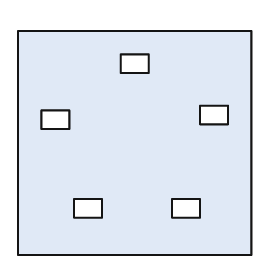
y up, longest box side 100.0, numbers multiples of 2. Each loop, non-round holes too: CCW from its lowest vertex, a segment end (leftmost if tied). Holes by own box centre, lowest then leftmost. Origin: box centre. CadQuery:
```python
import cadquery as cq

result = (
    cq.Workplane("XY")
    .moveTo(-50.0, -48.0)
    .lineTo(50.0, -48.0)
    .lineTo(50.0, 48.0)
    .lineTo(-50.0, 48.0)
    .close()
    .moveTo(-26.0, -32.0)
    .lineTo(-14.0, -32.0)
    .lineTo(-14.0, -24.0)
    .lineTo(-26.0, -24.0)
    .close()
    .moveTo(16.0, -32.0)
    .lineTo(28.0, -32.0)
    .lineTo(28.0, -24.0)
    .lineTo(16.0, -24.0)
    .close()
    .moveTo(-40.0, 6.0)
    .lineTo(-28.0, 6.0)
    .lineTo(-28.0, 14.0)
    .lineTo(-40.0, 14.0)
    .close()
    .moveTo(28.0, 8.0)
    .lineTo(40.0, 8.0)
    .lineTo(40.0, 16.0)
    .lineTo(28.0, 16.0)
    .close()
    .moveTo(-6.0, 30.0)
    .lineTo(6.0, 30.0)
    .lineTo(6.0, 38.0)
    .lineTo(-6.0, 38.0)
    .close()
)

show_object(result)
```